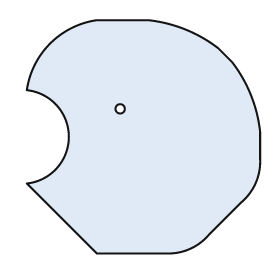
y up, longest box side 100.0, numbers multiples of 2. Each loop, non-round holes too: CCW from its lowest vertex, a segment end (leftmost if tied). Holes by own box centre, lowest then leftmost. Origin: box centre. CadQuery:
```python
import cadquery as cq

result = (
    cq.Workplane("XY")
    .moveTo(-20.0, -50.0)
    .lineTo(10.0, -50.0)
    .threePointArc((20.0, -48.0), (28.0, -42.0))
    .lineTo(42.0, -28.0)
    .threePointArc((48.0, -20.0), (50.0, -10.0))
    .lineTo(50.0, 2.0)
    .threePointArc((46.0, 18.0), (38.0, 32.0))
    .lineTo(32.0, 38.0)
    .threePointArc((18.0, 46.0), (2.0, 50.0))
    .lineTo(-20.0, 50.0)
    .threePointArc((-40.0, 40.0), (-50.0, 20.0))
    .threePointArc((-32.0, 0.0), (-50.0, -20.0))
    .close()
    .moveTo(-10.0, 12.0)
    .circle(2.0)
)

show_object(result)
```